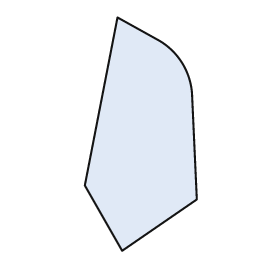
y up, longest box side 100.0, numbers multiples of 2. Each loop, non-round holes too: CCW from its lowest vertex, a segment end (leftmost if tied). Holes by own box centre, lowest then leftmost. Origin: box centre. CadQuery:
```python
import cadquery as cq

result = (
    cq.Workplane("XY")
    .moveTo(-8.0, -50.0)
    .lineTo(24.0, -28.0)
    .lineTo(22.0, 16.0)
    .threePointArc((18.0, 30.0), (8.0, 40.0))
    .lineTo(-10.0, 50.0)
    .lineTo(-24.0, -22.0)
    .close()
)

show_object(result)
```